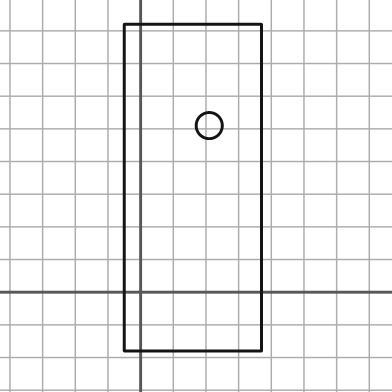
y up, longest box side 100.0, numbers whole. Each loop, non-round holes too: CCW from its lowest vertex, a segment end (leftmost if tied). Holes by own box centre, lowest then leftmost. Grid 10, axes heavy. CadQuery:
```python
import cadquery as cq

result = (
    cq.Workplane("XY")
    .moveTo(-5.0, -18.0)
    .lineTo(37.0, -18.0)
    .lineTo(37.0, 82.0)
    .lineTo(-5.0, 82.0)
    .close()
    .moveTo(21.0, 51.0)
    .circle(4.0)
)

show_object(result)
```